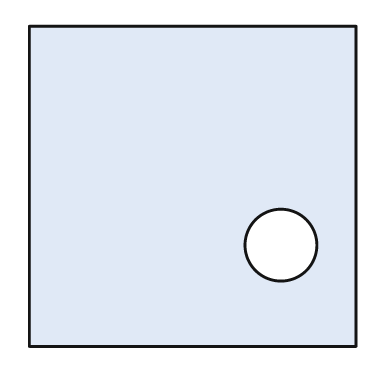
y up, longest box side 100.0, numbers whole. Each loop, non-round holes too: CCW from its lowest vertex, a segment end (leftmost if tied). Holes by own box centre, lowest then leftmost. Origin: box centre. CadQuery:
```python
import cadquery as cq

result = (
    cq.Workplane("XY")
    .moveTo(-50.0, -49.0)
    .lineTo(50.0, -49.0)
    .lineTo(50.0, 49.0)
    .lineTo(-50.0, 49.0)
    .close()
    .moveTo(27.0, -18.0)
    .circle(11.0)
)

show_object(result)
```